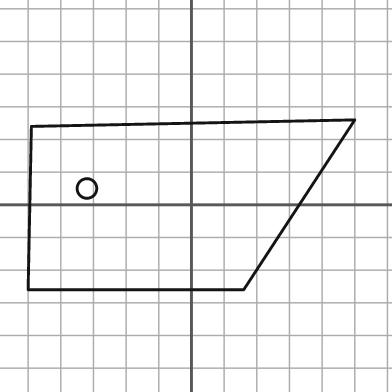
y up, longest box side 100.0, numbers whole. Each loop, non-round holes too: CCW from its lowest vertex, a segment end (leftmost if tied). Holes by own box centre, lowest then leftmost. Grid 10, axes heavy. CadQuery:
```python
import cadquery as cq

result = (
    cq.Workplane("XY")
    .moveTo(-50.0, -26.0)
    .lineTo(16.0, -26.0)
    .lineTo(50.0, 26.0)
    .lineTo(-49.0, 24.0)
    .close()
    .moveTo(-32.0, 5.0)
    .circle(3.0)
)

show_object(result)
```